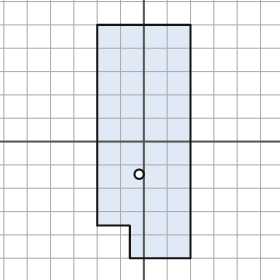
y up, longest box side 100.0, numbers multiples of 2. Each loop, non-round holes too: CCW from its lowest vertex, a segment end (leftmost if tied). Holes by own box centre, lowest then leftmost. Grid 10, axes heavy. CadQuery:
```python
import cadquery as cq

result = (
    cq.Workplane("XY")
    .moveTo(-6.0, -50.0)
    .lineTo(20.0, -50.0)
    .lineTo(20.0, 50.0)
    .lineTo(-20.0, 50.0)
    .lineTo(-20.0, -36.0)
    .lineTo(-6.0, -36.0)
    .close()
    .moveTo(-2.0, -14.0)
    .circle(2.0)
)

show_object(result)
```